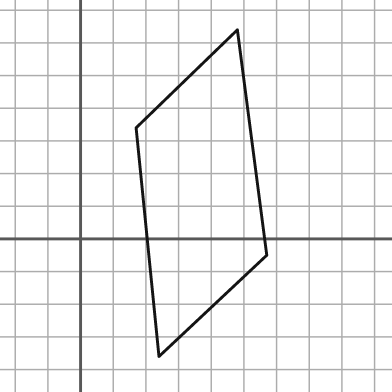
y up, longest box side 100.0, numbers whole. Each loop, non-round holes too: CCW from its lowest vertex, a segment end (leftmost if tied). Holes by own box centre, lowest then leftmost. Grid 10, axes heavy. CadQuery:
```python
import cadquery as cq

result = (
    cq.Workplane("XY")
    .moveTo(24.0, -36.0)
    .lineTo(57.0, -5.0)
    .lineTo(48.0, 64.0)
    .lineTo(17.0, 34.0)
    .close()
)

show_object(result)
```